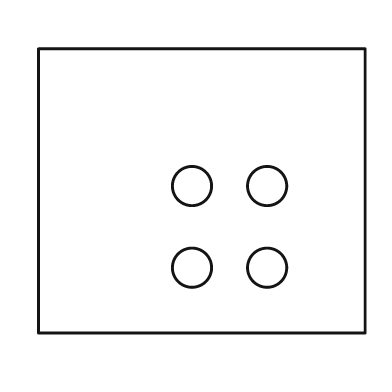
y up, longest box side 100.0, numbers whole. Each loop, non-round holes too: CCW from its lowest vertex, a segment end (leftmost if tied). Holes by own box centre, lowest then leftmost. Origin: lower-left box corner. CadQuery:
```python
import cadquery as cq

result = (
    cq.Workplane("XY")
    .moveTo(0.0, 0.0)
    .lineTo(100.0, 0.0)
    .lineTo(100.0, 87.0)
    .lineTo(0.0, 87.0)
    .close()
    .moveTo(47.0, 20.0)
    .circle(6.0)
    .moveTo(70.0, 20.0)
    .circle(6.0)
    .moveTo(47.0, 45.0)
    .circle(6.0)
    .moveTo(70.0, 45.0)
    .circle(6.0)
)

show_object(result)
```